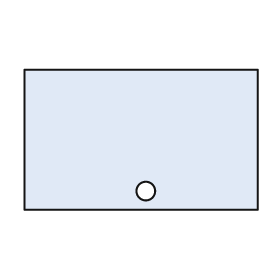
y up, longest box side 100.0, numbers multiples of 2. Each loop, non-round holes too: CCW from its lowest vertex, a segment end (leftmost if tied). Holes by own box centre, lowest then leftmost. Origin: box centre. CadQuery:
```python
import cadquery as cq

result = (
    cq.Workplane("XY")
    .moveTo(-50.0, -30.0)
    .lineTo(50.0, -30.0)
    .lineTo(50.0, 30.0)
    .lineTo(-50.0, 30.0)
    .close()
    .moveTo(2.0, -22.0)
    .circle(4.0)
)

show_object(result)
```